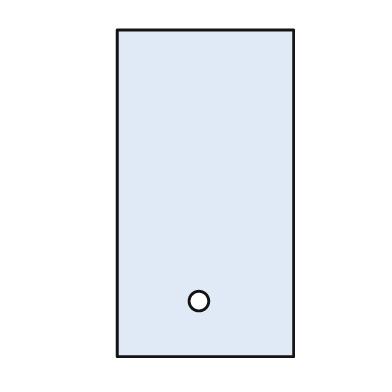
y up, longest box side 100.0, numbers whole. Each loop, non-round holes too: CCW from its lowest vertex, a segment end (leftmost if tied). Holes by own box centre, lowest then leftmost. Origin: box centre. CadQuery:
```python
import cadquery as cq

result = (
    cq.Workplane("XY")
    .moveTo(-27.0, -50.0)
    .lineTo(27.0, -50.0)
    .lineTo(27.0, 50.0)
    .lineTo(-27.0, 50.0)
    .close()
    .moveTo(-2.0, -33.0)
    .circle(3.0)
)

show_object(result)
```